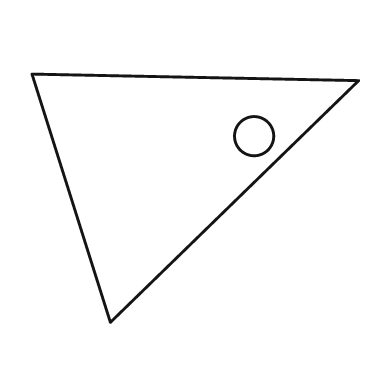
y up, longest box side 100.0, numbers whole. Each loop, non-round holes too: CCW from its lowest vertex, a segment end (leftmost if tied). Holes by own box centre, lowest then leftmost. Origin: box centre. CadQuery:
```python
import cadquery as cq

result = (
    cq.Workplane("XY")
    .moveTo(-26.0, -38.0)
    .lineTo(50.0, 36.0)
    .lineTo(-50.0, 38.0)
    .close()
    .moveTo(18.0, 19.0)
    .circle(6.0)
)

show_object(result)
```